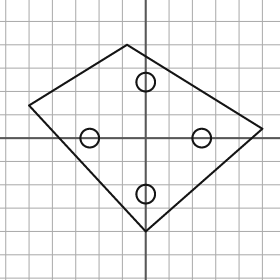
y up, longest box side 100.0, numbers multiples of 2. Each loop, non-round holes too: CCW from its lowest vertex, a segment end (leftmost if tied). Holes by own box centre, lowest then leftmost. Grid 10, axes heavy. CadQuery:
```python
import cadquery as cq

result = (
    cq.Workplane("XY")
    .moveTo(0.0, -40.0)
    .lineTo(50.0, 4.0)
    .lineTo(-8.0, 40.0)
    .lineTo(-50.0, 14.0)
    .close()
    .moveTo(0.0, -24.0)
    .circle(4.0)
    .moveTo(-24.0, 0.0)
    .circle(4.0)
    .moveTo(24.0, 0.0)
    .circle(4.0)
    .moveTo(0.0, 24.0)
    .circle(4.0)
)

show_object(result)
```